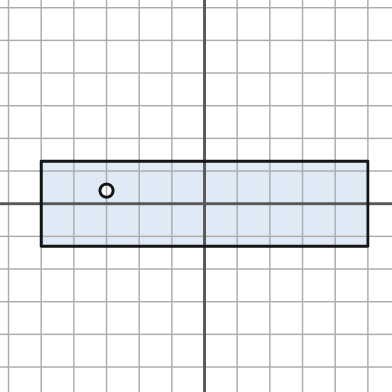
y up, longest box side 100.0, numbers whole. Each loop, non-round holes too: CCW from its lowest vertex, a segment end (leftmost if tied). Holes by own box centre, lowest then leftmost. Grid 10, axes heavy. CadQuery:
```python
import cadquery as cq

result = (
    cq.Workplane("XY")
    .moveTo(-50.0, -13.0)
    .lineTo(50.0, -13.0)
    .lineTo(50.0, 13.0)
    .lineTo(-50.0, 13.0)
    .close()
    .moveTo(-30.0, 4.0)
    .circle(2.0)
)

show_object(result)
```